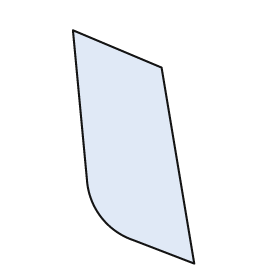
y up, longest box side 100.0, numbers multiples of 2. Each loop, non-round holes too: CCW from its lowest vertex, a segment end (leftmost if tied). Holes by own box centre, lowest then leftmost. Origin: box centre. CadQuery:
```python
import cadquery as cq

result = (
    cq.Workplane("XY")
    .moveTo(26.0, -50.0)
    .lineTo(12.0, 34.0)
    .lineTo(-26.0, 50.0)
    .lineTo(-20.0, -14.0)
    .threePointArc((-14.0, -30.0), (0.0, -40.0))
    .close()
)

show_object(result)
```